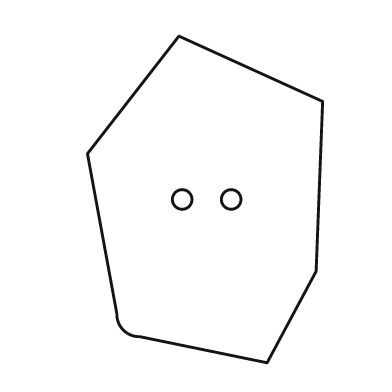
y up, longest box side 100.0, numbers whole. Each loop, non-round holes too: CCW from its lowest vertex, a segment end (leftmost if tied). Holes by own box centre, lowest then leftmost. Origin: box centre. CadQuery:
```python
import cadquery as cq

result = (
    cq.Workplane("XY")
    .moveTo(19.0, -50.0)
    .lineTo(34.0, -22.0)
    .lineTo(36.0, 30.0)
    .lineTo(-8.0, 50.0)
    .lineTo(-36.0, 14.0)
    .lineTo(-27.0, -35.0)
    .threePointArc((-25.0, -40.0), (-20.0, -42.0))
    .close()
    .moveTo(-7.0, 0.0)
    .circle(3.0)
    .moveTo(8.0, 0.0)
    .circle(3.0)
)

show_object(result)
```